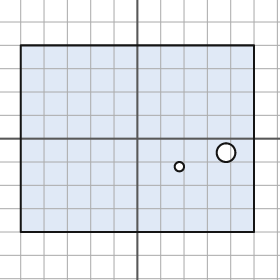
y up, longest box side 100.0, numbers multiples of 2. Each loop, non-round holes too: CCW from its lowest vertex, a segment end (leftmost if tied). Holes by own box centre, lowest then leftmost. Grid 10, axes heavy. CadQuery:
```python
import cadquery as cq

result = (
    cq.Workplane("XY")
    .moveTo(-50.0, -40.0)
    .lineTo(50.0, -40.0)
    .lineTo(50.0, 40.0)
    .lineTo(-50.0, 40.0)
    .close()
    .moveTo(18.0, -12.0)
    .circle(2.0)
    .moveTo(38.0, -6.0)
    .circle(4.0)
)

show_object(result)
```